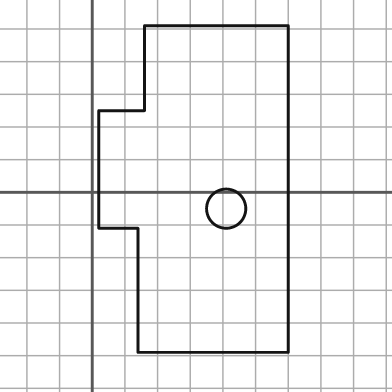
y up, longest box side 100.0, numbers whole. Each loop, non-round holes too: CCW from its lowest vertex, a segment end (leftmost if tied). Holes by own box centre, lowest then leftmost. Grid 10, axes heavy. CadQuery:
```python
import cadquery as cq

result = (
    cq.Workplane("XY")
    .moveTo(14.0, -49.0)
    .lineTo(60.0, -49.0)
    .lineTo(60.0, 51.0)
    .lineTo(16.0, 51.0)
    .lineTo(16.0, 25.0)
    .lineTo(2.0, 25.0)
    .lineTo(2.0, -11.0)
    .lineTo(14.0, -11.0)
    .close()
    .moveTo(41.0, -5.0)
    .circle(6.0)
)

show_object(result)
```